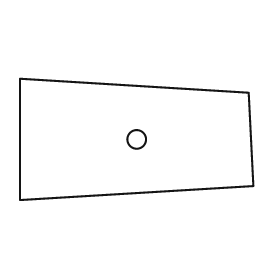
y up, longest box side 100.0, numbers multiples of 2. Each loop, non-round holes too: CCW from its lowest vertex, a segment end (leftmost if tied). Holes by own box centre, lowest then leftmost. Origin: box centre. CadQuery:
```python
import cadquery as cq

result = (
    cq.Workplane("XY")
    .moveTo(-50.0, -26.0)
    .lineTo(50.0, -20.0)
    .lineTo(48.0, 20.0)
    .lineTo(-50.0, 26.0)
    .close()
    .moveTo(0.0, 0.0)
    .circle(4.0)
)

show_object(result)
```